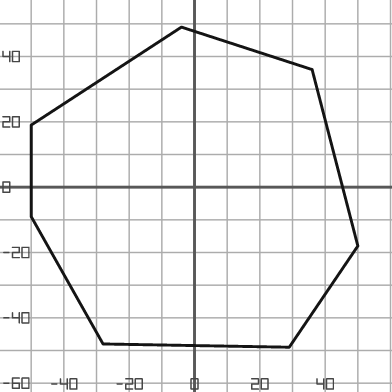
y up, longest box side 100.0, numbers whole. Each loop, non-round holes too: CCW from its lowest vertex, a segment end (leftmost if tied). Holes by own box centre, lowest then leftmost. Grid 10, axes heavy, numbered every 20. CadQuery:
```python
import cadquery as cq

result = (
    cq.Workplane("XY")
    .moveTo(29.0, -49.0)
    .lineTo(50.0, -18.0)
    .lineTo(36.0, 36.0)
    .lineTo(-4.0, 49.0)
    .lineTo(-50.0, 19.0)
    .lineTo(-50.0, -9.0)
    .lineTo(-28.0, -48.0)
    .close()
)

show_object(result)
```